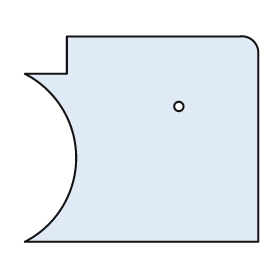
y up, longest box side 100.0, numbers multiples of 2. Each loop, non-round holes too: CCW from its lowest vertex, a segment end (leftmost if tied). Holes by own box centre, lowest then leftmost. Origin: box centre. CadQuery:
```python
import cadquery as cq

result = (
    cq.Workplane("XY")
    .moveTo(-50.0, -44.0)
    .lineTo(50.0, -44.0)
    .lineTo(50.0, 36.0)
    .threePointArc((48.0, 42.0), (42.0, 44.0))
    .lineTo(-32.0, 44.0)
    .lineTo(-32.0, 28.0)
    .lineTo(-50.0, 28.0)
    .threePointArc((-28.0, -8.0), (-50.0, -44.0))
    .close()
    .moveTo(16.0, 14.0)
    .circle(2.0)
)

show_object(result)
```